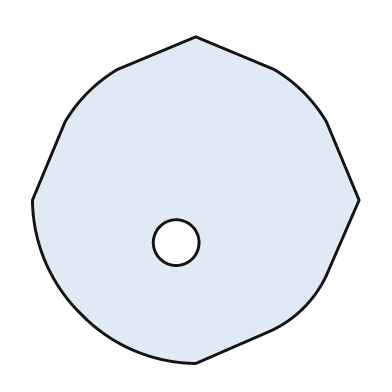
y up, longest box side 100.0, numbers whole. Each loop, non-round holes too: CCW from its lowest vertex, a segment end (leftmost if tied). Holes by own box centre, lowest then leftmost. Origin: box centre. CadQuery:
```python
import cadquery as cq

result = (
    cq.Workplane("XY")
    .moveTo(0.0, -50.0)
    .lineTo(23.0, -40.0)
    .threePointArc((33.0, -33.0), (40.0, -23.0))
    .lineTo(50.0, 0.0)
    .lineTo(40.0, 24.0)
    .threePointArc((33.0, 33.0), (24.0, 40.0))
    .lineTo(0.0, 50.0)
    .lineTo(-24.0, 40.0)
    .threePointArc((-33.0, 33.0), (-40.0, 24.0))
    .lineTo(-50.0, 0.0)
    .threePointArc((-46.0, -19.0), (-35.0, -35.0))
    .threePointArc((-19.0, -46.0), (0.0, -50.0))
    .close()
    .moveTo(-6.0, -13.0)
    .circle(7.0)
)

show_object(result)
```